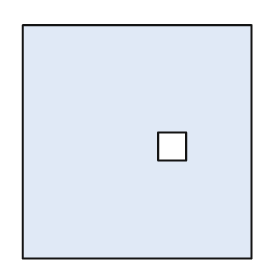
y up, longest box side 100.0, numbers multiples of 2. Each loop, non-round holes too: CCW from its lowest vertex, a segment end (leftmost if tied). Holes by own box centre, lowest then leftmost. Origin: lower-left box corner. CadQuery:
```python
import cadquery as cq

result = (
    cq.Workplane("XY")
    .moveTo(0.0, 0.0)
    .lineTo(98.0, 0.0)
    .lineTo(98.0, 100.0)
    .lineTo(0.0, 100.0)
    .close()
    .moveTo(58.0, 42.0)
    .lineTo(70.0, 42.0)
    .lineTo(70.0, 54.0)
    .lineTo(58.0, 54.0)
    .close()
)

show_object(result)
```